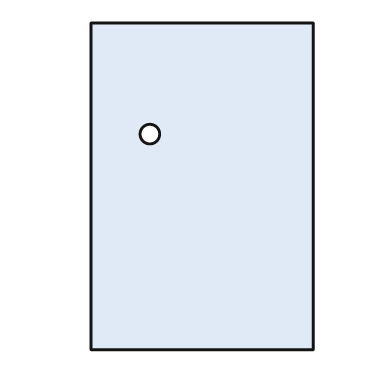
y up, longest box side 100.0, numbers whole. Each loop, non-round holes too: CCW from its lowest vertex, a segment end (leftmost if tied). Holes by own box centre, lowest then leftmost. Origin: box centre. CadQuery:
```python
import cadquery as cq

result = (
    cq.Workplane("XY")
    .moveTo(-34.0, -50.0)
    .lineTo(34.0, -50.0)
    .lineTo(34.0, 50.0)
    .lineTo(-34.0, 50.0)
    .close()
    .moveTo(-16.0, 16.0)
    .circle(3.0)
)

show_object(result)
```